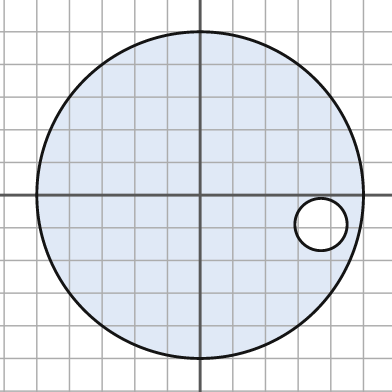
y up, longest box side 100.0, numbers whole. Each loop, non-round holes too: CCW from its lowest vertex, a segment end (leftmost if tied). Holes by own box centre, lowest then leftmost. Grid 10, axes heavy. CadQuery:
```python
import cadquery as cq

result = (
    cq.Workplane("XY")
    .moveTo(0.0, 0.0)
    .circle(50.0)
    .moveTo(37.0, -9.0)
    .circle(8.0)
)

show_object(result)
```